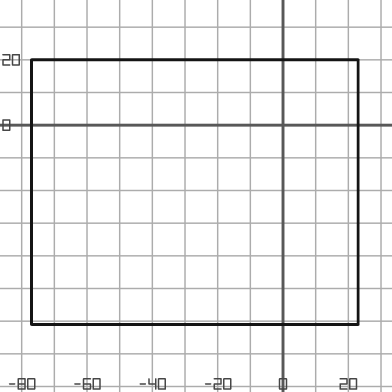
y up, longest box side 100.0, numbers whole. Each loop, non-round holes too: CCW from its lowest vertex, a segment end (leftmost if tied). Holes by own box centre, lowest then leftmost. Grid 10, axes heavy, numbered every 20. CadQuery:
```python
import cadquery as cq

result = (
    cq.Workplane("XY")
    .moveTo(-77.0, -61.0)
    .lineTo(23.0, -61.0)
    .lineTo(23.0, 20.0)
    .lineTo(-77.0, 20.0)
    .close()
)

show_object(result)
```